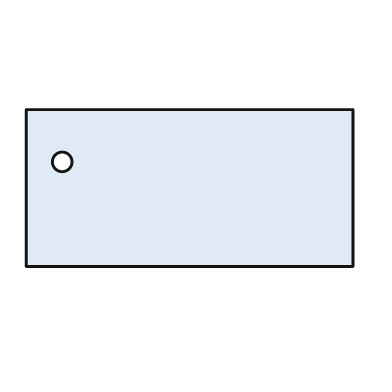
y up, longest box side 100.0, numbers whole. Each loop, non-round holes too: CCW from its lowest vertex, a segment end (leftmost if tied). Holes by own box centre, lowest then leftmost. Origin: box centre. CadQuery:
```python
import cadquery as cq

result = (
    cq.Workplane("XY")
    .moveTo(-50.0, -24.0)
    .lineTo(50.0, -24.0)
    .lineTo(50.0, 24.0)
    .lineTo(-50.0, 24.0)
    .close()
    .moveTo(-39.0, 8.0)
    .circle(3.0)
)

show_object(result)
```